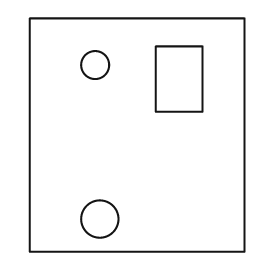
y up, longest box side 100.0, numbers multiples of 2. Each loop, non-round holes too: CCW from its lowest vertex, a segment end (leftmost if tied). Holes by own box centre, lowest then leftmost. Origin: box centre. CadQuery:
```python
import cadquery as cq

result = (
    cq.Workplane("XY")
    .moveTo(-46.0, -50.0)
    .lineTo(46.0, -50.0)
    .lineTo(46.0, 50.0)
    .lineTo(-46.0, 50.0)
    .close()
    .moveTo(-16.0, -36.0)
    .circle(8.0)
    .moveTo(8.0, 10.0)
    .lineTo(28.0, 10.0)
    .lineTo(28.0, 38.0)
    .lineTo(8.0, 38.0)
    .close()
    .moveTo(-18.0, 30.0)
    .circle(6.0)
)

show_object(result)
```